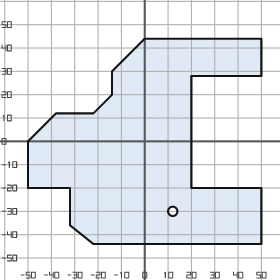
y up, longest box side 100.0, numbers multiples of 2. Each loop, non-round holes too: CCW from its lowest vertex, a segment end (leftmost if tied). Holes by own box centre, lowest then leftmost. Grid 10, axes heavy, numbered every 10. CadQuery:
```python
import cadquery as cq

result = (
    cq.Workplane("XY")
    .moveTo(-22.0, -44.0)
    .lineTo(50.0, -44.0)
    .lineTo(50.0, -20.0)
    .lineTo(20.0, -20.0)
    .lineTo(20.0, 28.0)
    .lineTo(50.0, 28.0)
    .lineTo(50.0, 44.0)
    .lineTo(0.0, 44.0)
    .lineTo(-14.0, 30.0)
    .lineTo(-14.0, 20.0)
    .lineTo(-22.0, 12.0)
    .lineTo(-38.0, 12.0)
    .lineTo(-50.0, 0.0)
    .lineTo(-50.0, -20.0)
    .lineTo(-32.0, -20.0)
    .lineTo(-32.0, -36.0)
    .close()
    .moveTo(12.0, -30.0)
    .circle(2.0)
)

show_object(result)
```